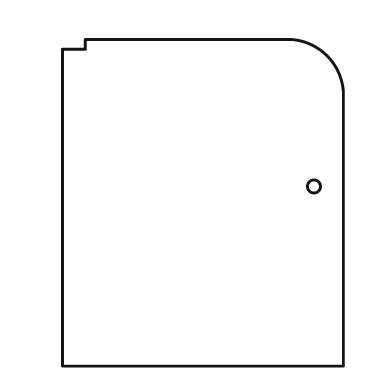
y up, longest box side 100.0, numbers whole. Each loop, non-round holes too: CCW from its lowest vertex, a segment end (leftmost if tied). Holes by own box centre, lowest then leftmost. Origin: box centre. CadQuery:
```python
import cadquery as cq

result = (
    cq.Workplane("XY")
    .moveTo(-43.0, -50.0)
    .lineTo(43.0, -50.0)
    .lineTo(43.0, 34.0)
    .threePointArc((38.0, 45.0), (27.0, 50.0))
    .lineTo(-36.0, 50.0)
    .lineTo(-36.0, 47.0)
    .lineTo(-43.0, 47.0)
    .close()
    .moveTo(34.0, 5.0)
    .circle(2.0)
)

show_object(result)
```